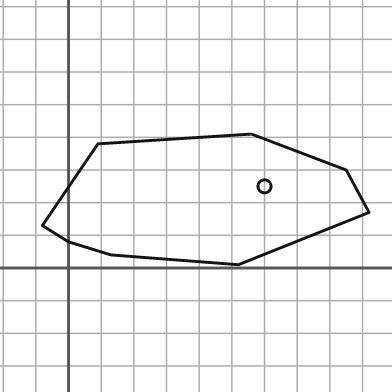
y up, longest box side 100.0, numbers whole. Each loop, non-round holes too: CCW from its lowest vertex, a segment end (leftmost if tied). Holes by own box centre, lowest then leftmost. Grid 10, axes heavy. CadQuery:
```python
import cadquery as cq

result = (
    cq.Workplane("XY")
    .moveTo(52.0, 1.0)
    .lineTo(92.0, 17.0)
    .lineTo(85.0, 30.0)
    .lineTo(56.0, 41.0)
    .lineTo(9.0, 38.0)
    .lineTo(-8.0, 13.0)
    .lineTo(0.0, 8.0)
    .lineTo(13.0, 4.0)
    .close()
    .moveTo(60.0, 25.0)
    .circle(2.0)
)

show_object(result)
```